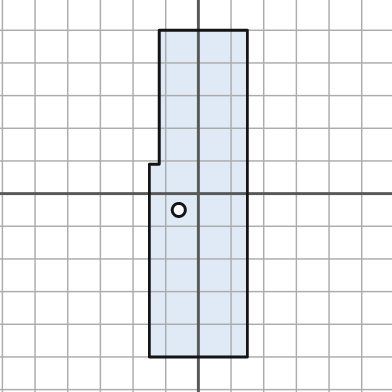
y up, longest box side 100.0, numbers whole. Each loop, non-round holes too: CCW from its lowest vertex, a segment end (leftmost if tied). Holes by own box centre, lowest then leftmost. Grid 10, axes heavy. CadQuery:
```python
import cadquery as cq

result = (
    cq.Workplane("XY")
    .moveTo(-15.0, -50.0)
    .lineTo(15.0, -50.0)
    .lineTo(15.0, 50.0)
    .lineTo(-12.0, 50.0)
    .lineTo(-12.0, 9.0)
    .lineTo(-15.0, 9.0)
    .close()
    .moveTo(-6.0, -5.0)
    .circle(2.0)
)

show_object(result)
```